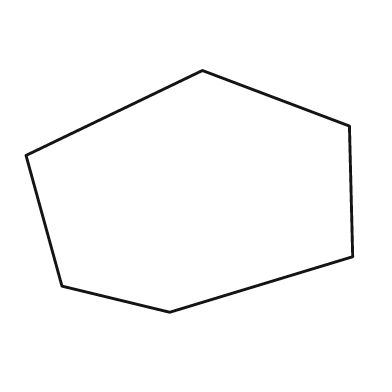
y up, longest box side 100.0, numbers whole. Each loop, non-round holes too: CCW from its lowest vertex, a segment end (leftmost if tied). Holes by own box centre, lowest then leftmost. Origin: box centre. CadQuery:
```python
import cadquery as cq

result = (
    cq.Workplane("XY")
    .moveTo(-6.0, -37.0)
    .lineTo(50.0, -20.0)
    .lineTo(49.0, 20.0)
    .lineTo(4.0, 37.0)
    .lineTo(-50.0, 11.0)
    .lineTo(-39.0, -29.0)
    .close()
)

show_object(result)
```